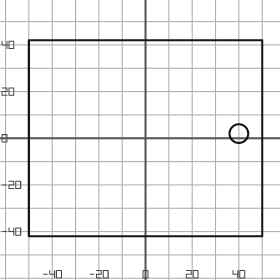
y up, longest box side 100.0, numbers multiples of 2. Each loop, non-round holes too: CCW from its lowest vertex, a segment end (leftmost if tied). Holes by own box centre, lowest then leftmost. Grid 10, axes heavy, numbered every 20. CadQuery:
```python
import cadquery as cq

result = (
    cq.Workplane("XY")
    .moveTo(-50.0, -42.0)
    .lineTo(50.0, -42.0)
    .lineTo(50.0, 42.0)
    .lineTo(-50.0, 42.0)
    .close()
    .moveTo(40.0, 2.0)
    .circle(4.0)
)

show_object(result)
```